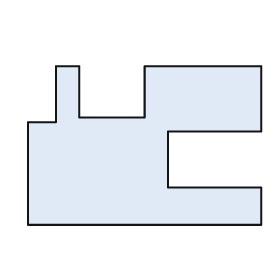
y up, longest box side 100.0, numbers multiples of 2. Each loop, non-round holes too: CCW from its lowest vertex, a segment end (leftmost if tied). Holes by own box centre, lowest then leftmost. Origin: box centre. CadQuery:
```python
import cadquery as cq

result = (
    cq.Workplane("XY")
    .moveTo(-50.0, -34.0)
    .lineTo(50.0, -34.0)
    .lineTo(50.0, -18.0)
    .lineTo(10.0, -18.0)
    .lineTo(10.0, 6.0)
    .lineTo(50.0, 6.0)
    .lineTo(50.0, 34.0)
    .lineTo(0.0, 34.0)
    .lineTo(0.0, 12.0)
    .lineTo(-28.0, 12.0)
    .lineTo(-28.0, 34.0)
    .lineTo(-38.0, 34.0)
    .lineTo(-38.0, 10.0)
    .lineTo(-50.0, 10.0)
    .close()
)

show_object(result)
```